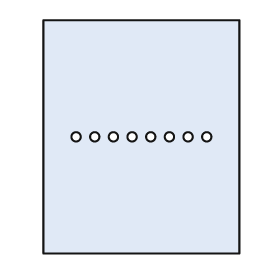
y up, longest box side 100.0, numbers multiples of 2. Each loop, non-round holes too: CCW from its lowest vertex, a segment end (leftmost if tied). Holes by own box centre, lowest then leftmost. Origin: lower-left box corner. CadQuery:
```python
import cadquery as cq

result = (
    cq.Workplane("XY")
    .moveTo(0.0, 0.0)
    .lineTo(84.0, 0.0)
    .lineTo(84.0, 100.0)
    .lineTo(0.0, 100.0)
    .close()
    .moveTo(14.0, 50.0)
    .circle(2.0)
    .moveTo(22.0, 50.0)
    .circle(2.0)
    .moveTo(30.0, 50.0)
    .circle(2.0)
    .moveTo(38.0, 50.0)
    .circle(2.0)
    .moveTo(46.0, 50.0)
    .circle(2.0)
    .moveTo(54.0, 50.0)
    .circle(2.0)
    .moveTo(62.0, 50.0)
    .circle(2.0)
    .moveTo(70.0, 50.0)
    .circle(2.0)
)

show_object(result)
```